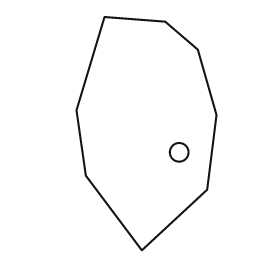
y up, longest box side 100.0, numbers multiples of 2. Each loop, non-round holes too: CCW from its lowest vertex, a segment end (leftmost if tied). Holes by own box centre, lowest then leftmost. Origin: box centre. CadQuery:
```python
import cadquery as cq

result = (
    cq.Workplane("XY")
    .moveTo(-2.0, -50.0)
    .lineTo(26.0, -24.0)
    .lineTo(30.0, 8.0)
    .lineTo(22.0, 36.0)
    .lineTo(8.0, 48.0)
    .lineTo(-18.0, 50.0)
    .lineTo(-30.0, 10.0)
    .lineTo(-26.0, -18.0)
    .close()
    .moveTo(14.0, -8.0)
    .circle(4.0)
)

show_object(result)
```